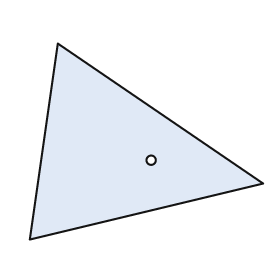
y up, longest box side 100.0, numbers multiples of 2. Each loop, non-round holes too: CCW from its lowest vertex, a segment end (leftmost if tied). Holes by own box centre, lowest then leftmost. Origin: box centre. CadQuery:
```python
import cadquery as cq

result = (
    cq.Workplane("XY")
    .moveTo(-50.0, -42.0)
    .lineTo(50.0, -18.0)
    .lineTo(-38.0, 42.0)
    .close()
    .moveTo(2.0, -8.0)
    .circle(2.0)
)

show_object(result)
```